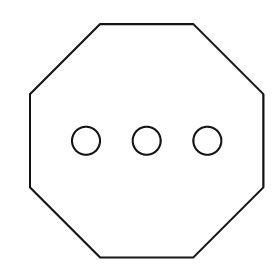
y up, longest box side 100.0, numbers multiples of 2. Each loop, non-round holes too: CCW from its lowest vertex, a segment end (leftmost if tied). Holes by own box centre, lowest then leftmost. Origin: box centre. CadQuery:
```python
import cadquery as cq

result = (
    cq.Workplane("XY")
    .moveTo(-20.0, -50.0)
    .lineTo(20.0, -50.0)
    .lineTo(50.0, -20.0)
    .lineTo(50.0, 20.0)
    .lineTo(20.0, 50.0)
    .lineTo(-20.0, 50.0)
    .lineTo(-50.0, 20.0)
    .lineTo(-50.0, -20.0)
    .close()
    .moveTo(-26.0, 0.0)
    .circle(6.0)
    .moveTo(0.0, 0.0)
    .circle(6.0)
    .moveTo(26.0, 0.0)
    .circle(6.0)
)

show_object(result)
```